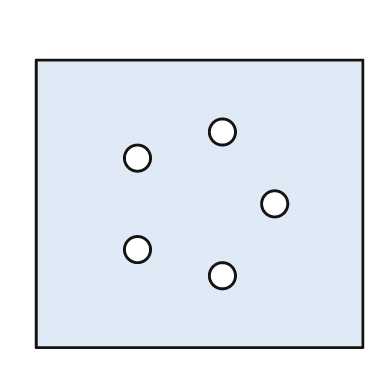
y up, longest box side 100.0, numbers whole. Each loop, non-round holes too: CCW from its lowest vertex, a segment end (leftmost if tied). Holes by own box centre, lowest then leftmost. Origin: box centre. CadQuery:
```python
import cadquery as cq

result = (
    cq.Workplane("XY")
    .moveTo(-50.0, -44.0)
    .lineTo(50.0, -44.0)
    .lineTo(50.0, 44.0)
    .lineTo(-50.0, 44.0)
    .close()
    .moveTo(7.0, -22.0)
    .circle(4.0)
    .moveTo(-19.0, -14.0)
    .circle(4.0)
    .moveTo(23.0, 0.0)
    .circle(4.0)
    .moveTo(-19.0, 14.0)
    .circle(4.0)
    .moveTo(7.0, 22.0)
    .circle(4.0)
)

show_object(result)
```